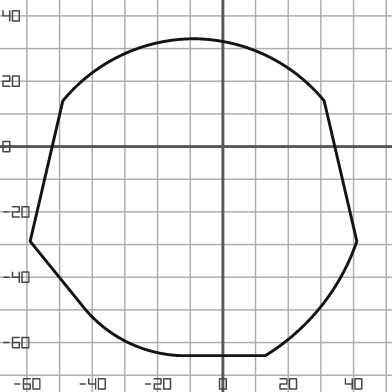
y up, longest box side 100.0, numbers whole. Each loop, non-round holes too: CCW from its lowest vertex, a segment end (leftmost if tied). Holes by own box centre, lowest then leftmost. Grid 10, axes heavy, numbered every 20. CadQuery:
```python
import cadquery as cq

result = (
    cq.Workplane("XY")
    .moveTo(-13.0, -64.0)
    .lineTo(13.0, -64.0)
    .threePointArc((30.0, -49.0), (41.0, -29.0))
    .lineTo(31.0, 14.0)
    .threePointArc((13.0, 28.0), (-9.0, 33.0))
    .threePointArc((-31.0, 28.0), (-49.0, 14.0))
    .lineTo(-59.0, -29.0)
    .lineTo(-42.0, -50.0)
    .threePointArc((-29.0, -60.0), (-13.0, -64.0))
    .close()
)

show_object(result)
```